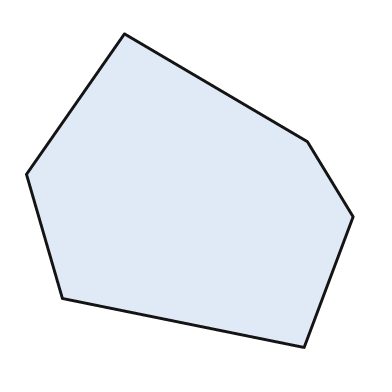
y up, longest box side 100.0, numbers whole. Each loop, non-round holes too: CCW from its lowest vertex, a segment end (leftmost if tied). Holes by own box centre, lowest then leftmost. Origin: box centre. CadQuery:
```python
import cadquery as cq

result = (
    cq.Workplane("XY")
    .moveTo(35.0, -48.0)
    .lineTo(50.0, -8.0)
    .lineTo(36.0, 15.0)
    .lineTo(-20.0, 48.0)
    .lineTo(-50.0, 5.0)
    .lineTo(-39.0, -33.0)
    .close()
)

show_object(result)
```